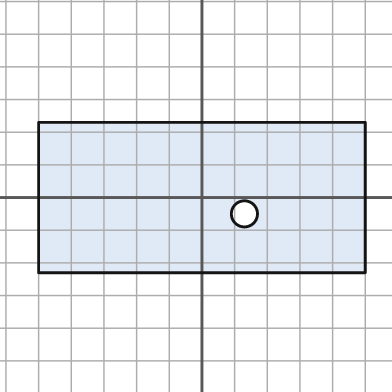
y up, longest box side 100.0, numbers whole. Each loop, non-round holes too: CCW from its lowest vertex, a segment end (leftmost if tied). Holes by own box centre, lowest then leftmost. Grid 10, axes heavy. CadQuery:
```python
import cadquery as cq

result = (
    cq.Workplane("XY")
    .moveTo(-50.0, -23.0)
    .lineTo(50.0, -23.0)
    .lineTo(50.0, 23.0)
    .lineTo(-50.0, 23.0)
    .close()
    .moveTo(13.0, -5.0)
    .circle(4.0)
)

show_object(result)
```